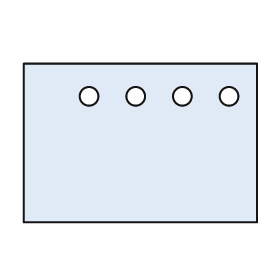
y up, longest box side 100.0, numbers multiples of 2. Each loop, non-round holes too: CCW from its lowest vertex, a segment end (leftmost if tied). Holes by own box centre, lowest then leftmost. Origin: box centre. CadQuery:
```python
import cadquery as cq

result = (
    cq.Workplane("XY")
    .moveTo(-50.0, -34.0)
    .lineTo(50.0, -34.0)
    .lineTo(50.0, 34.0)
    .lineTo(-50.0, 34.0)
    .close()
    .moveTo(-22.0, 20.0)
    .circle(4.0)
    .moveTo(-2.0, 20.0)
    .circle(4.0)
    .moveTo(18.0, 20.0)
    .circle(4.0)
    .moveTo(38.0, 20.0)
    .circle(4.0)
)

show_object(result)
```